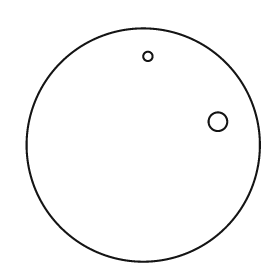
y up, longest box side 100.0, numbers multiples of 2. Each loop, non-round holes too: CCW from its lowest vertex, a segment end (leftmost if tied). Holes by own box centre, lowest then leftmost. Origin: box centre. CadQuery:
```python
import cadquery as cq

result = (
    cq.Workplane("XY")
    .moveTo(0.0, 0.0)
    .circle(50.0)
    .moveTo(32.0, 10.0)
    .circle(4.0)
    .moveTo(2.0, 38.0)
    .circle(2.0)
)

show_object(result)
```